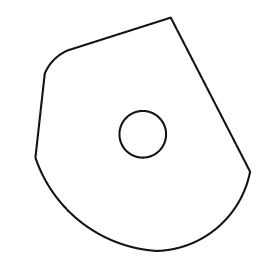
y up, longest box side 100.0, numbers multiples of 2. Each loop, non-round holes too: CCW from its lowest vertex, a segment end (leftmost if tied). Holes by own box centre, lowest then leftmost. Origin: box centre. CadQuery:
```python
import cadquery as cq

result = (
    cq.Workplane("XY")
    .moveTo(6.0, -50.0)
    .threePointArc((32.0, -40.0), (46.0, -16.0))
    .lineTo(12.0, 50.0)
    .lineTo(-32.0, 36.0)
    .threePointArc((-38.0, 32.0), (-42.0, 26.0))
    .lineTo(-46.0, -10.0)
    .threePointArc((-26.0, -38.0), (6.0, -50.0))
    .close()
    .moveTo(0.0, 0.0)
    .circle(10.0)
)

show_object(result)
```